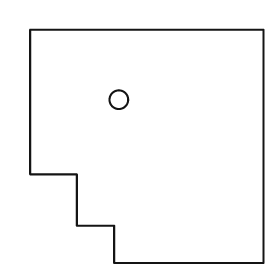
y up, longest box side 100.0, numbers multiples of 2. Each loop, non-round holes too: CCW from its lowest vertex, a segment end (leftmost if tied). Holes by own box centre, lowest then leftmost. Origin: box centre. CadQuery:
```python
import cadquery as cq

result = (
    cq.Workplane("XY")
    .moveTo(-14.0, -50.0)
    .lineTo(50.0, -50.0)
    .lineTo(50.0, 50.0)
    .lineTo(-50.0, 50.0)
    .lineTo(-50.0, -12.0)
    .lineTo(-30.0, -12.0)
    .lineTo(-30.0, -34.0)
    .lineTo(-14.0, -34.0)
    .close()
    .moveTo(-12.0, 20.0)
    .circle(4.0)
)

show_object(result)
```